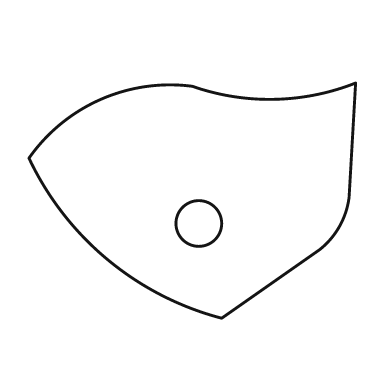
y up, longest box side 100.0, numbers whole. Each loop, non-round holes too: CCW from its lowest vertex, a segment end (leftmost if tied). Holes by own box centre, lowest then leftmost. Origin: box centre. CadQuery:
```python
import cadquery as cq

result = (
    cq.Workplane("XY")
    .moveTo(9.0, -36.0)
    .lineTo(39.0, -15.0)
    .threePointArc((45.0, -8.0), (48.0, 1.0))
    .lineTo(50.0, 36.0)
    .threePointArc((25.0, 31.0), (0.0, 35.0))
    .threePointArc((-28.0, 31.0), (-50.0, 13.0))
    .threePointArc((-26.0, -18.0), (9.0, -36.0))
    .close()
    .moveTo(2.0, -7.0)
    .circle(7.0)
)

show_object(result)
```